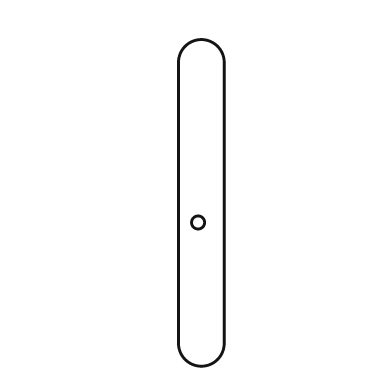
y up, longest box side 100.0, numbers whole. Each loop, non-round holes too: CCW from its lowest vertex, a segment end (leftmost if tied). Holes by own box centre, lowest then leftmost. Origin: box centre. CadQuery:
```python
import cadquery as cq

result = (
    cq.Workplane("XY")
    .moveTo(-7.0, -43.0)
    .threePointArc((0.0, -50.0), (7.0, -43.0))
    .lineTo(7.0, 43.0)
    .threePointArc((0.0, 50.0), (-7.0, 43.0))
    .close()
    .moveTo(-1.0, -6.0)
    .circle(2.0)
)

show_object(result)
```